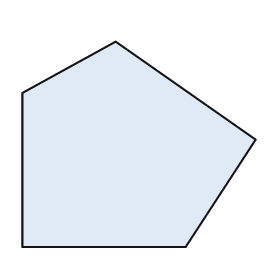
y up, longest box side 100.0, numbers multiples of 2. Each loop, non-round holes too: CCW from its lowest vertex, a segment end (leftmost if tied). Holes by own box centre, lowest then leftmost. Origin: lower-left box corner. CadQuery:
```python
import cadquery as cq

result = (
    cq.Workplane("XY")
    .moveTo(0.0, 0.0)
    .lineTo(70.0, 0.0)
    .lineTo(100.0, 46.0)
    .lineTo(40.0, 88.0)
    .lineTo(0.0, 66.0)
    .close()
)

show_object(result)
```